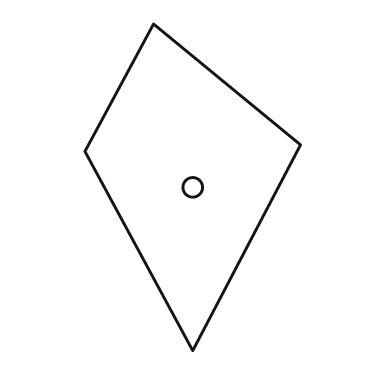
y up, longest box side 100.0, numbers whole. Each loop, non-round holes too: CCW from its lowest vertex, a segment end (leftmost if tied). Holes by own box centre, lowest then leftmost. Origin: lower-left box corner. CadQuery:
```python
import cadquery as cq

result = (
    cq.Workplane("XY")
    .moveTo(33.0, 0.0)
    .lineTo(66.0, 63.0)
    .lineTo(21.0, 100.0)
    .lineTo(0.0, 61.0)
    .close()
    .moveTo(33.0, 50.0)
    .circle(3.0)
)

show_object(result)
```